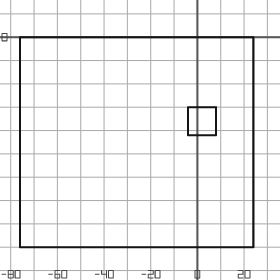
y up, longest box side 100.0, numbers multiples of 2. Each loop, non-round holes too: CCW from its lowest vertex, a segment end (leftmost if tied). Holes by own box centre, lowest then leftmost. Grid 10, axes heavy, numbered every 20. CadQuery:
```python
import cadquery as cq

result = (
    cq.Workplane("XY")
    .moveTo(-76.0, -90.0)
    .lineTo(24.0, -90.0)
    .lineTo(24.0, 0.0)
    .lineTo(-76.0, 0.0)
    .close()
    .moveTo(-4.0, -42.0)
    .lineTo(8.0, -42.0)
    .lineTo(8.0, -30.0)
    .lineTo(-4.0, -30.0)
    .close()
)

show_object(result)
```